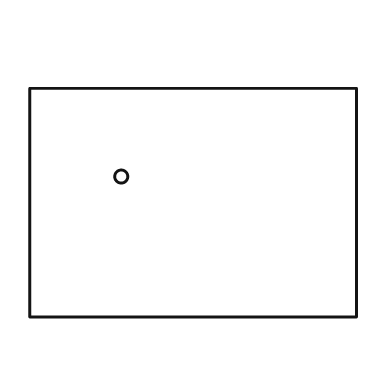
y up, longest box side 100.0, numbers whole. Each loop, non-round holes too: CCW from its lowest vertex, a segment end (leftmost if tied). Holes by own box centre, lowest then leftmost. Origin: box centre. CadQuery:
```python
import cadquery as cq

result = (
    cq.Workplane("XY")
    .moveTo(-50.0, -35.0)
    .lineTo(50.0, -35.0)
    .lineTo(50.0, 35.0)
    .lineTo(-50.0, 35.0)
    .close()
    .moveTo(-22.0, 8.0)
    .circle(2.0)
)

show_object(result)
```